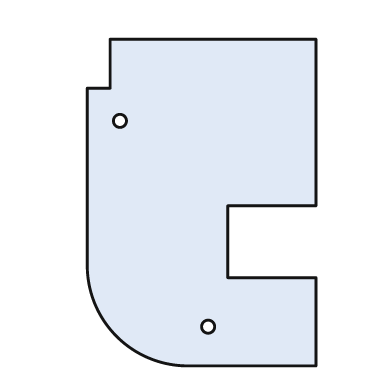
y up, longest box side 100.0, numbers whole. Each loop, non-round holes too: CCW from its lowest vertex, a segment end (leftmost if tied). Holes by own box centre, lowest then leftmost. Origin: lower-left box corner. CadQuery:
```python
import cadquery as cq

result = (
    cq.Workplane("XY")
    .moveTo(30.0, 0.0)
    .lineTo(70.0, 0.0)
    .lineTo(70.0, 27.0)
    .lineTo(43.0, 27.0)
    .lineTo(43.0, 49.0)
    .lineTo(70.0, 49.0)
    .lineTo(70.0, 100.0)
    .lineTo(7.0, 100.0)
    .lineTo(7.0, 85.0)
    .lineTo(0.0, 85.0)
    .lineTo(0.0, 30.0)
    .threePointArc((9.0, 9.0), (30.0, 0.0))
    .close()
    .moveTo(37.0, 12.0)
    .circle(2.0)
    .moveTo(10.0, 75.0)
    .circle(2.0)
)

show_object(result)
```